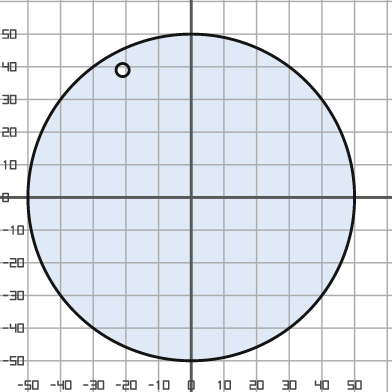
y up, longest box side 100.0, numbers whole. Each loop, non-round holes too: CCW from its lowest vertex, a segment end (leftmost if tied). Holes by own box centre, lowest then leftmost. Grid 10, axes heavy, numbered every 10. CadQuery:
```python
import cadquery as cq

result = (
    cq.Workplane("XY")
    .moveTo(0.0, 0.0)
    .circle(50.0)
    .moveTo(-21.0, 39.0)
    .circle(2.0)
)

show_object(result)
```